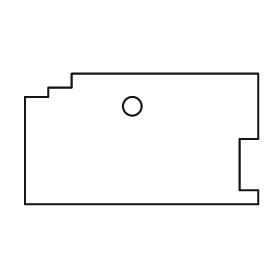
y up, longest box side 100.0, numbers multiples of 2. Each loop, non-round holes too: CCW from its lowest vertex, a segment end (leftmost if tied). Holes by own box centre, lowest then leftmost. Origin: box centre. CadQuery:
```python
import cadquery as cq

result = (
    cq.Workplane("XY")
    .moveTo(-50.0, -28.0)
    .lineTo(50.0, -28.0)
    .lineTo(50.0, -22.0)
    .lineTo(42.0, -22.0)
    .lineTo(42.0, 0.0)
    .lineTo(50.0, 0.0)
    .lineTo(50.0, 28.0)
    .lineTo(-30.0, 28.0)
    .lineTo(-30.0, 22.0)
    .lineTo(-40.0, 22.0)
    .lineTo(-40.0, 18.0)
    .lineTo(-50.0, 18.0)
    .close()
    .moveTo(-4.0, 14.0)
    .circle(4.0)
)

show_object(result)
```